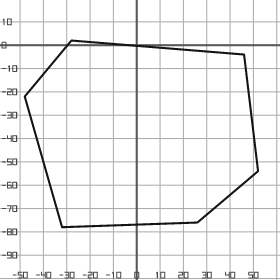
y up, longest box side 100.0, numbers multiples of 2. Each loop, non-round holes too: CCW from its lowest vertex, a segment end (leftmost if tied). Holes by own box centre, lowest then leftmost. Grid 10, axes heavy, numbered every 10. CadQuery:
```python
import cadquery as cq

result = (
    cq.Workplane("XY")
    .moveTo(-32.0, -78.0)
    .lineTo(26.0, -76.0)
    .lineTo(52.0, -54.0)
    .lineTo(46.0, -4.0)
    .lineTo(-28.0, 2.0)
    .lineTo(-48.0, -22.0)
    .close()
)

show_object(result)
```